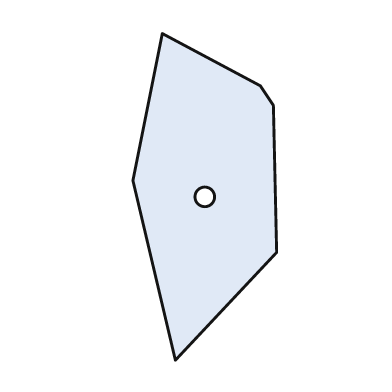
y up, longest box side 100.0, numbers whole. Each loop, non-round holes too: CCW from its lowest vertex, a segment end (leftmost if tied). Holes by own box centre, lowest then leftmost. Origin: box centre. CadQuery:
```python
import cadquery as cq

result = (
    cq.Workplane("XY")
    .moveTo(-9.0, -50.0)
    .lineTo(22.0, -17.0)
    .lineTo(21.0, 28.0)
    .lineTo(17.0, 34.0)
    .lineTo(-13.0, 50.0)
    .lineTo(-22.0, 5.0)
    .close()
    .moveTo(0.0, 0.0)
    .circle(3.0)
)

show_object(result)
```